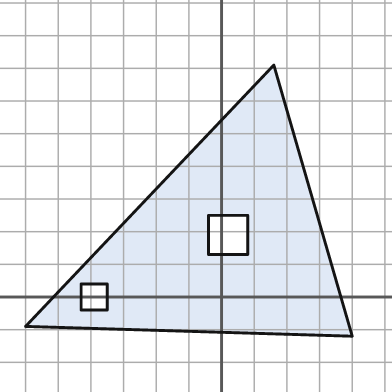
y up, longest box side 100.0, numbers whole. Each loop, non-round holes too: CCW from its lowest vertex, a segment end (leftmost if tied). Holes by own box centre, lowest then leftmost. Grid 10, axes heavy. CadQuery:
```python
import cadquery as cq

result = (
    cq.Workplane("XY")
    .moveTo(40.0, -12.0)
    .lineTo(16.0, 71.0)
    .lineTo(-60.0, -9.0)
    .close()
    .moveTo(-43.0, -4.0)
    .lineTo(-35.0, -4.0)
    .lineTo(-35.0, 4.0)
    .lineTo(-43.0, 4.0)
    .close()
    .moveTo(-4.0, 13.0)
    .lineTo(8.0, 13.0)
    .lineTo(8.0, 25.0)
    .lineTo(-4.0, 25.0)
    .close()
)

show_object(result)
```